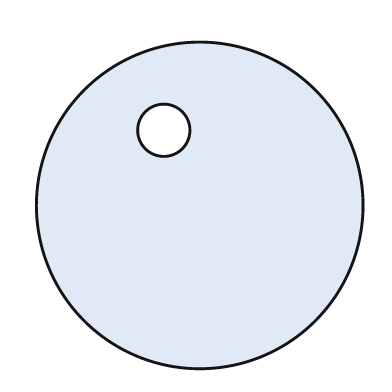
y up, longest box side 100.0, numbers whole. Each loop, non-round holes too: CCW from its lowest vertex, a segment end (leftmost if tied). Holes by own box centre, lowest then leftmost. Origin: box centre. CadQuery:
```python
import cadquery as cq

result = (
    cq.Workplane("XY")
    .moveTo(0.0, 0.0)
    .circle(50.0)
    .moveTo(-11.0, 23.0)
    .circle(8.0)
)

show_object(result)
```